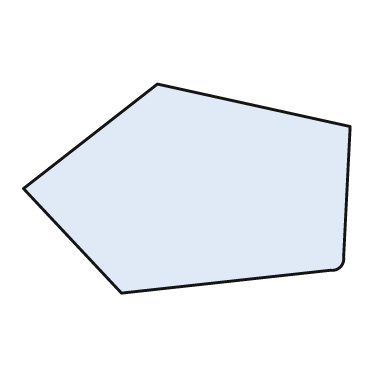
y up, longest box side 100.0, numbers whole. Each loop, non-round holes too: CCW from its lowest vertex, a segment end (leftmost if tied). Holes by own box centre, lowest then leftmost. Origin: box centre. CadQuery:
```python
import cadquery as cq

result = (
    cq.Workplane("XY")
    .moveTo(-20.0, -32.0)
    .lineTo(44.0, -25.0)
    .threePointArc((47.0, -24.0), (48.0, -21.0))
    .lineTo(50.0, 19.0)
    .lineTo(-9.0, 32.0)
    .lineTo(-50.0, 0.0)
    .close()
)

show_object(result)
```